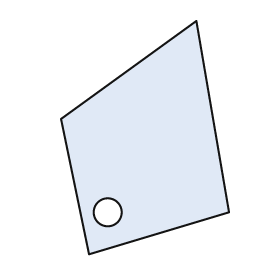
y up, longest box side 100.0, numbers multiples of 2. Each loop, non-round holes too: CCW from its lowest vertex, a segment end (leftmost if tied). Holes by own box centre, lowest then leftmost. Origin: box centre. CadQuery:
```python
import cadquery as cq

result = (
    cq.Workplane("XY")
    .moveTo(-24.0, -50.0)
    .lineTo(36.0, -32.0)
    .lineTo(22.0, 50.0)
    .lineTo(-36.0, 8.0)
    .close()
    .moveTo(-16.0, -32.0)
    .circle(6.0)
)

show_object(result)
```